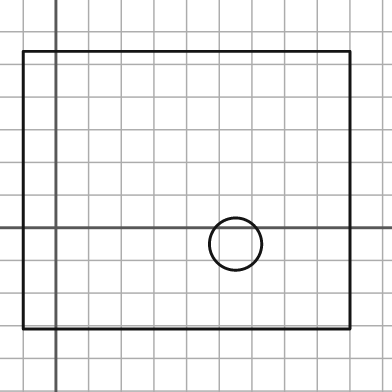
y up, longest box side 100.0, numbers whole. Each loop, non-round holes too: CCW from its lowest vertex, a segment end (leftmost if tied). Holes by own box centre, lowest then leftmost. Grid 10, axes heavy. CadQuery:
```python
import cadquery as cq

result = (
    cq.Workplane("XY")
    .moveTo(-10.0, -31.0)
    .lineTo(90.0, -31.0)
    .lineTo(90.0, 54.0)
    .lineTo(-10.0, 54.0)
    .close()
    .moveTo(55.0, -5.0)
    .circle(8.0)
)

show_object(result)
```